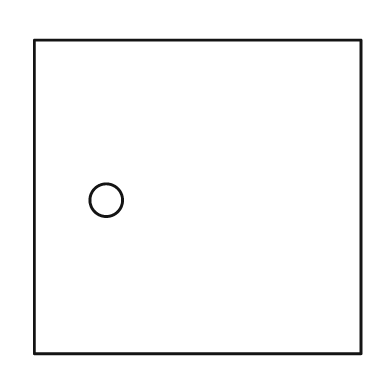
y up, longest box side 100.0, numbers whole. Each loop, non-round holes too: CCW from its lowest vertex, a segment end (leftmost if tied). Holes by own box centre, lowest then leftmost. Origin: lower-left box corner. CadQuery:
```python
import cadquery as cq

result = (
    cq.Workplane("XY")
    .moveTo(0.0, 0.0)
    .lineTo(100.0, 0.0)
    .lineTo(100.0, 96.0)
    .lineTo(0.0, 96.0)
    .close()
    .moveTo(22.0, 47.0)
    .circle(5.0)
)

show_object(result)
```